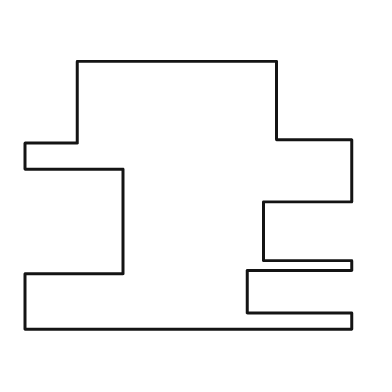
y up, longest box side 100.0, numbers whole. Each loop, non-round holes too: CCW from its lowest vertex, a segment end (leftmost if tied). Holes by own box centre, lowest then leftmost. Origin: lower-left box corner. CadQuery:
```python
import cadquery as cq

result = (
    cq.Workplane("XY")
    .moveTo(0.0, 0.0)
    .lineTo(100.0, 0.0)
    .lineTo(100.0, 5.0)
    .lineTo(68.0, 5.0)
    .lineTo(68.0, 18.0)
    .lineTo(100.0, 18.0)
    .lineTo(100.0, 21.0)
    .lineTo(73.0, 21.0)
    .lineTo(73.0, 39.0)
    .lineTo(100.0, 39.0)
    .lineTo(100.0, 58.0)
    .lineTo(77.0, 58.0)
    .lineTo(77.0, 82.0)
    .lineTo(16.0, 82.0)
    .lineTo(16.0, 57.0)
    .lineTo(0.0, 57.0)
    .lineTo(0.0, 49.0)
    .lineTo(30.0, 49.0)
    .lineTo(30.0, 17.0)
    .lineTo(0.0, 17.0)
    .close()
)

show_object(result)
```